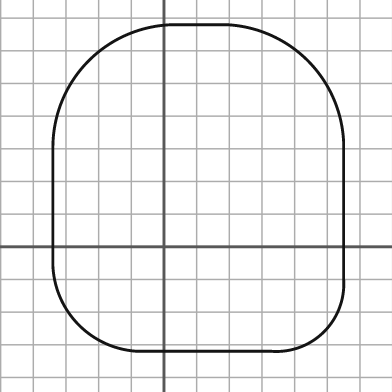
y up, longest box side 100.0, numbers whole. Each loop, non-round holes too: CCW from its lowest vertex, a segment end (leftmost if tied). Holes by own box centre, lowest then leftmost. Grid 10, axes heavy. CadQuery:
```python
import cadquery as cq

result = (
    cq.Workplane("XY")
    .moveTo(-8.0, -32.0)
    .lineTo(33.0, -32.0)
    .threePointArc((49.0, -26.0), (55.0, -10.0))
    .lineTo(55.0, 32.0)
    .threePointArc((44.0, 57.0), (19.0, 68.0))
    .lineTo(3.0, 68.0)
    .threePointArc((-23.0, 57.0), (-34.0, 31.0))
    .lineTo(-34.0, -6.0)
    .threePointArc((-26.0, -24.0), (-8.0, -32.0))
    .close()
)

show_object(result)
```